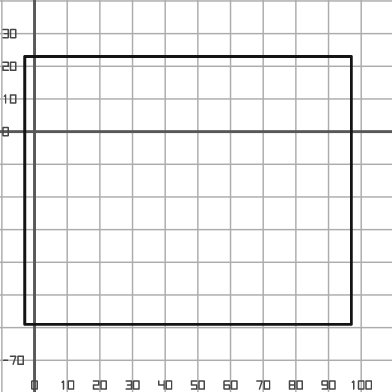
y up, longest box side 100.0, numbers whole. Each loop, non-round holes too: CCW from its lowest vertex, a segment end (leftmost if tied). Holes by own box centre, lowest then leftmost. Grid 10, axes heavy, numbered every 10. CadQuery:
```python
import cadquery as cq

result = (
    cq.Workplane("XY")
    .moveTo(-3.0, -59.0)
    .lineTo(97.0, -59.0)
    .lineTo(97.0, 23.0)
    .lineTo(-3.0, 23.0)
    .close()
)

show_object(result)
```